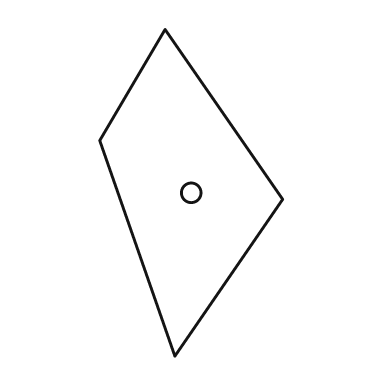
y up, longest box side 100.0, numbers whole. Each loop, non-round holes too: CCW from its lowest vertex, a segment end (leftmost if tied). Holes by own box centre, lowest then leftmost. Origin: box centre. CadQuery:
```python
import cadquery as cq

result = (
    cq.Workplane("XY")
    .moveTo(-5.0, -50.0)
    .lineTo(28.0, -2.0)
    .lineTo(-8.0, 50.0)
    .lineTo(-28.0, 16.0)
    .close()
    .moveTo(0.0, 0.0)
    .circle(3.0)
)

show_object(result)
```